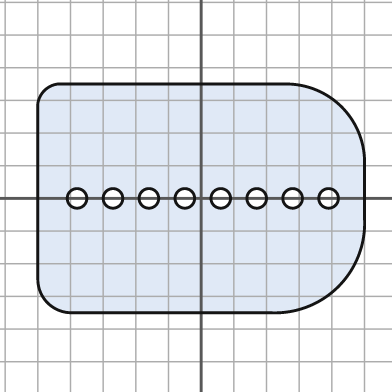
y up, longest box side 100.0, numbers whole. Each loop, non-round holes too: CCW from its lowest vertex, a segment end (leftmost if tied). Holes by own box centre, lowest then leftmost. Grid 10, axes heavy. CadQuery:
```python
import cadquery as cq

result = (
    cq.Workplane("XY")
    .moveTo(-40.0, -35.0)
    .lineTo(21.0, -35.0)
    .threePointArc((42.0, -27.0), (50.0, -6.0))
    .lineTo(50.0, 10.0)
    .threePointArc((43.0, 28.0), (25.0, 35.0))
    .lineTo(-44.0, 35.0)
    .threePointArc((-48.0, 33.0), (-50.0, 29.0))
    .lineTo(-50.0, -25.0)
    .threePointArc((-47.0, -32.0), (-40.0, -35.0))
    .close()
    .moveTo(-38.0, 0.0)
    .circle(3.0)
    .moveTo(-27.0, 0.0)
    .circle(3.0)
    .moveTo(-16.0, 0.0)
    .circle(3.0)
    .moveTo(-5.0, 0.0)
    .circle(3.0)
    .moveTo(6.0, 0.0)
    .circle(3.0)
    .moveTo(17.0, 0.0)
    .circle(3.0)
    .moveTo(28.0, 0.0)
    .circle(3.0)
    .moveTo(39.0, 0.0)
    .circle(3.0)
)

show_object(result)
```